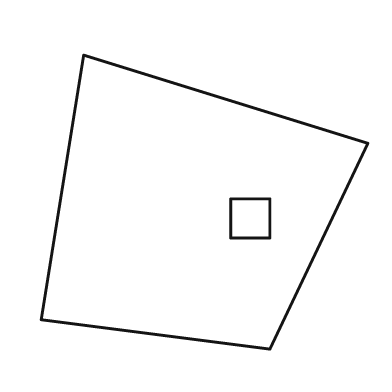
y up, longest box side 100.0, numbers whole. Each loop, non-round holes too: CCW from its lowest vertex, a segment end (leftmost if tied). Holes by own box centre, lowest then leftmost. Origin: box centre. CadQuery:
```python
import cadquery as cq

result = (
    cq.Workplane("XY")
    .moveTo(20.0, -45.0)
    .lineTo(50.0, 18.0)
    .lineTo(-37.0, 45.0)
    .lineTo(-50.0, -36.0)
    .close()
    .moveTo(8.0, -11.0)
    .lineTo(20.0, -11.0)
    .lineTo(20.0, 1.0)
    .lineTo(8.0, 1.0)
    .close()
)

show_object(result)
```